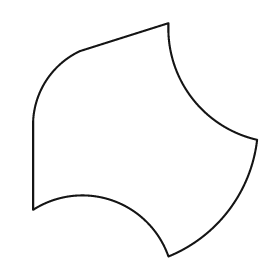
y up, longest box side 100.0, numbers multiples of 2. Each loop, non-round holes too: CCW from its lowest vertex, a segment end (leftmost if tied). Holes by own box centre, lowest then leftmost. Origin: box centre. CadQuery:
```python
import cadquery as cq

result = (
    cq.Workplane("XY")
    .moveTo(10.0, -50.0)
    .threePointArc((36.0, -30.0), (48.0, 0.0))
    .threePointArc((20.0, 18.0), (10.0, 50.0))
    .lineTo(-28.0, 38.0)
    .threePointArc((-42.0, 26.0), (-48.0, 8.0))
    .lineTo(-48.0, -30.0)
    .threePointArc((-14.0, -26.0), (10.0, -50.0))
    .close()
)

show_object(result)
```